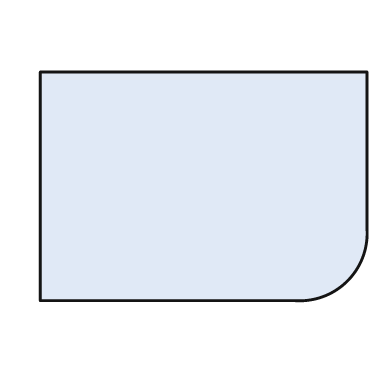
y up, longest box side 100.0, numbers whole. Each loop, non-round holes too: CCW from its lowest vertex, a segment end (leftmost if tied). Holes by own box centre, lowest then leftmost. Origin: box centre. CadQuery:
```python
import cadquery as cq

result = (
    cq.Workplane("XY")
    .moveTo(-50.0, -35.0)
    .lineTo(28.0, -35.0)
    .threePointArc((44.0, -29.0), (50.0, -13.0))
    .lineTo(50.0, 35.0)
    .lineTo(-50.0, 35.0)
    .close()
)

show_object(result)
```